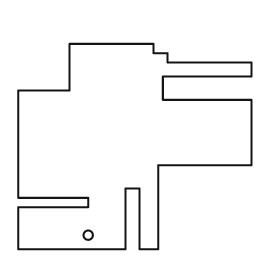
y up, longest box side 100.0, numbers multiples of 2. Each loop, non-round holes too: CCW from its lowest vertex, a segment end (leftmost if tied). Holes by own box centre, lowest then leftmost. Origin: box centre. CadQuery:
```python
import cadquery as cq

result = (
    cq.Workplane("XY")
    .moveTo(-50.0, -44.0)
    .lineTo(-4.0, -44.0)
    .lineTo(-4.0, -18.0)
    .lineTo(2.0, -18.0)
    .lineTo(2.0, -44.0)
    .lineTo(10.0, -44.0)
    .lineTo(10.0, -8.0)
    .lineTo(50.0, -8.0)
    .lineTo(50.0, 20.0)
    .lineTo(12.0, 20.0)
    .lineTo(12.0, 30.0)
    .lineTo(50.0, 30.0)
    .lineTo(50.0, 36.0)
    .lineTo(14.0, 36.0)
    .lineTo(14.0, 40.0)
    .lineTo(8.0, 40.0)
    .lineTo(8.0, 44.0)
    .lineTo(-28.0, 44.0)
    .lineTo(-28.0, 24.0)
    .lineTo(-50.0, 24.0)
    .lineTo(-50.0, -22.0)
    .lineTo(-20.0, -22.0)
    .lineTo(-20.0, -26.0)
    .lineTo(-50.0, -26.0)
    .close()
    .moveTo(-20.0, -38.0)
    .circle(2.0)
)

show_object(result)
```